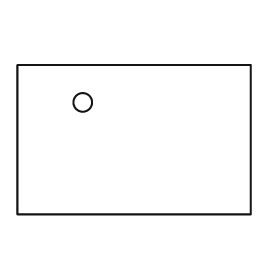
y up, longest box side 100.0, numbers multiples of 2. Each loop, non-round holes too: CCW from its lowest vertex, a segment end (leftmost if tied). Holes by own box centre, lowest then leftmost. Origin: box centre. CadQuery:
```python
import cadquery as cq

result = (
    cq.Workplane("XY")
    .moveTo(-50.0, -32.0)
    .lineTo(50.0, -32.0)
    .lineTo(50.0, 32.0)
    .lineTo(-50.0, 32.0)
    .close()
    .moveTo(-22.0, 16.0)
    .circle(4.0)
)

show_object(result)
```